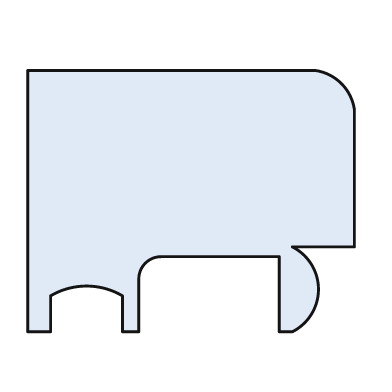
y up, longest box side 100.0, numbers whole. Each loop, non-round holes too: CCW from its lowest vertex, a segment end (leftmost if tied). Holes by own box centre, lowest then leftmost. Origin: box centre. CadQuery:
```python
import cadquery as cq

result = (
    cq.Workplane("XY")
    .moveTo(-50.0, -40.0)
    .lineTo(-43.0, -40.0)
    .lineTo(-43.0, -29.0)
    .threePointArc((-32.0, -26.0), (-21.0, -29.0))
    .lineTo(-21.0, -40.0)
    .lineTo(-16.0, -40.0)
    .lineTo(-16.0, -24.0)
    .threePointArc((-14.0, -19.0), (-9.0, -17.0))
    .lineTo(27.0, -17.0)
    .lineTo(27.0, -40.0)
    .lineTo(31.0, -40.0)
    .threePointArc((39.0, -27.0), (31.0, -14.0))
    .lineTo(50.0, -14.0)
    .lineTo(50.0, 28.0)
    .threePointArc((46.0, 36.0), (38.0, 40.0))
    .lineTo(-50.0, 40.0)
    .close()
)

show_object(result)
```